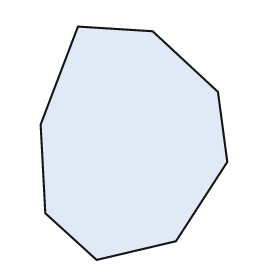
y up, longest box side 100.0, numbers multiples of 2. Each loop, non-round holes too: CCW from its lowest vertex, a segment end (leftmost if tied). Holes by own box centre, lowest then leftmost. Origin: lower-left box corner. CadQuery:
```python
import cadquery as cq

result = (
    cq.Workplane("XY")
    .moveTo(24.0, 0.0)
    .lineTo(58.0, 8.0)
    .lineTo(80.0, 42.0)
    .lineTo(76.0, 72.0)
    .lineTo(48.0, 98.0)
    .lineTo(16.0, 100.0)
    .lineTo(0.0, 58.0)
    .lineTo(2.0, 20.0)
    .close()
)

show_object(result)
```